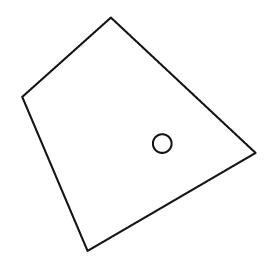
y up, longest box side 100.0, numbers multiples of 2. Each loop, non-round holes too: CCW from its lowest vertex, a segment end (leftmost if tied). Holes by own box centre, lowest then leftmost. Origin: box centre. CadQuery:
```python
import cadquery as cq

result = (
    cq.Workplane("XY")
    .moveTo(-22.0, -50.0)
    .lineTo(50.0, -8.0)
    .lineTo(-12.0, 50.0)
    .lineTo(-50.0, 16.0)
    .close()
    .moveTo(10.0, -4.0)
    .circle(4.0)
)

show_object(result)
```